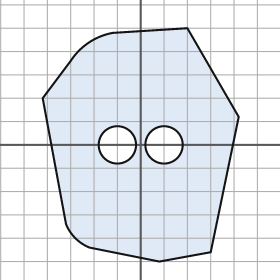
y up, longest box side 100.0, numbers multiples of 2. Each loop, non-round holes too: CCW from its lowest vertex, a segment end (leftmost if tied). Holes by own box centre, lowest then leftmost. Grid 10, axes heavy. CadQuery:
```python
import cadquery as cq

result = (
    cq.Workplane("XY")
    .moveTo(8.0, -50.0)
    .lineTo(30.0, -46.0)
    .lineTo(42.0, 12.0)
    .lineTo(20.0, 50.0)
    .lineTo(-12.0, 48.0)
    .threePointArc((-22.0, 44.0), (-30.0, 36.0))
    .lineTo(-42.0, 20.0)
    .lineTo(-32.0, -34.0)
    .threePointArc((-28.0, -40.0), (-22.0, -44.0))
    .close()
    .moveTo(-10.0, 0.0)
    .circle(8.0)
    .moveTo(10.0, 0.0)
    .circle(8.0)
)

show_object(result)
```